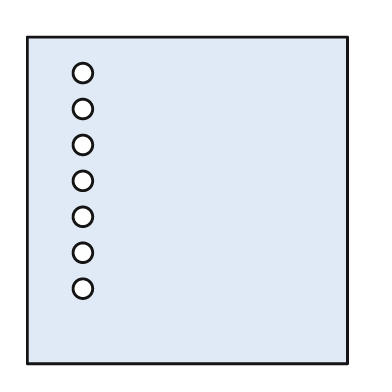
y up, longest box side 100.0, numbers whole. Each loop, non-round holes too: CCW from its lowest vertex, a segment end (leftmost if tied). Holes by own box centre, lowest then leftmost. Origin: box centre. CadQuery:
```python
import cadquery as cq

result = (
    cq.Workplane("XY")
    .moveTo(-49.0, -50.0)
    .lineTo(49.0, -50.0)
    .lineTo(49.0, 50.0)
    .lineTo(-49.0, 50.0)
    .close()
    .moveTo(-32.0, -27.0)
    .circle(3.0)
    .moveTo(-32.0, -16.0)
    .circle(3.0)
    .moveTo(-32.0, -5.0)
    .circle(3.0)
    .moveTo(-32.0, 6.0)
    .circle(3.0)
    .moveTo(-32.0, 17.0)
    .circle(3.0)
    .moveTo(-32.0, 28.0)
    .circle(3.0)
    .moveTo(-32.0, 39.0)
    .circle(3.0)
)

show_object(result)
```